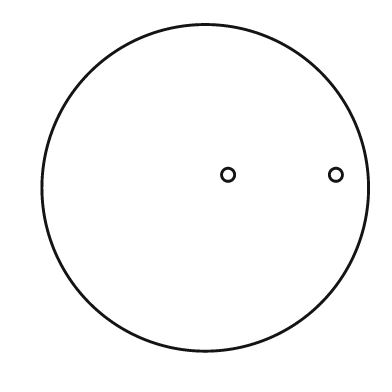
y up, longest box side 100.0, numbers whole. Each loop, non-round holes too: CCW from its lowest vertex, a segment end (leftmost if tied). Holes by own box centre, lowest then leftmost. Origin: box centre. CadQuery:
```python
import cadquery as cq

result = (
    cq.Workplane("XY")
    .moveTo(0.0, 0.0)
    .circle(50.0)
    .moveTo(7.0, 4.0)
    .circle(2.0)
    .moveTo(40.0, 4.0)
    .circle(2.0)
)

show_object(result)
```